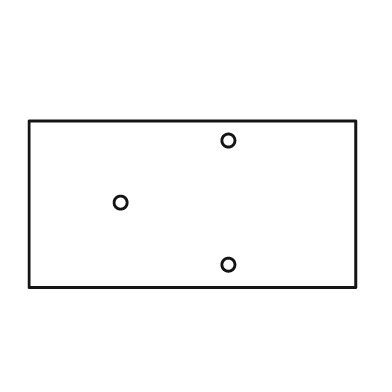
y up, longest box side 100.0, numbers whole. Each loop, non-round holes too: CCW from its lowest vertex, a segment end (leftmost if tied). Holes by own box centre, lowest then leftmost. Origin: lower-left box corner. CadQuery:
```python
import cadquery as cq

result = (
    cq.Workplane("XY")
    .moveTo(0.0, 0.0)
    .lineTo(100.0, 0.0)
    .lineTo(100.0, 51.0)
    .lineTo(0.0, 51.0)
    .close()
    .moveTo(61.0, 7.0)
    .circle(2.0)
    .moveTo(28.0, 26.0)
    .circle(2.0)
    .moveTo(61.0, 45.0)
    .circle(2.0)
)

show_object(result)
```